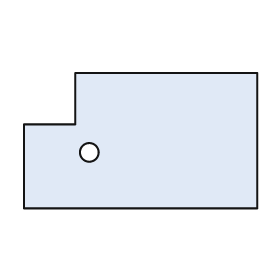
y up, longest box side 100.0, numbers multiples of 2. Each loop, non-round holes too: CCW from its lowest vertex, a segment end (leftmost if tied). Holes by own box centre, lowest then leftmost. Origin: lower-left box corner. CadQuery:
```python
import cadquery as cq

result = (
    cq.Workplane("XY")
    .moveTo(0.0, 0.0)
    .lineTo(100.0, 0.0)
    .lineTo(100.0, 58.0)
    .lineTo(22.0, 58.0)
    .lineTo(22.0, 36.0)
    .lineTo(0.0, 36.0)
    .close()
    .moveTo(28.0, 24.0)
    .circle(4.0)
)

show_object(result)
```